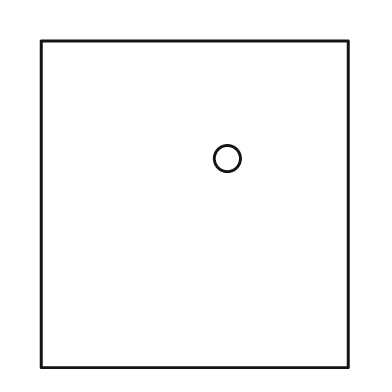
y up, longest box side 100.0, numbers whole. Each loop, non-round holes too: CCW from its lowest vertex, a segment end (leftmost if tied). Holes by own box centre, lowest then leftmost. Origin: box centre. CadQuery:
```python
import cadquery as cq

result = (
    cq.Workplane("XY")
    .moveTo(-47.0, -50.0)
    .lineTo(47.0, -50.0)
    .lineTo(47.0, 50.0)
    .lineTo(-47.0, 50.0)
    .close()
    .moveTo(10.0, 14.0)
    .circle(4.0)
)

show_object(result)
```